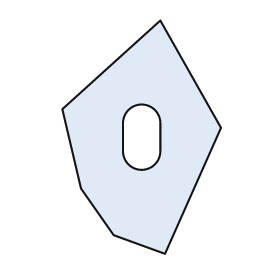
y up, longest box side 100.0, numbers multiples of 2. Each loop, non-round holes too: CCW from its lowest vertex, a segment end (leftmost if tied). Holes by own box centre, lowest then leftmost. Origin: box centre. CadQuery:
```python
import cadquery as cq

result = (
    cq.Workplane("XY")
    .moveTo(10.0, -50.0)
    .lineTo(34.0, 4.0)
    .lineTo(8.0, 50.0)
    .lineTo(-34.0, 12.0)
    .lineTo(-26.0, -22.0)
    .lineTo(-12.0, -42.0)
    .close()
    .moveTo(-8.0, -6.0)
    .threePointArc((0.0, -14.0), (8.0, -6.0))
    .lineTo(8.0, 6.0)
    .threePointArc((0.0, 14.0), (-8.0, 6.0))
    .close()
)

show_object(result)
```